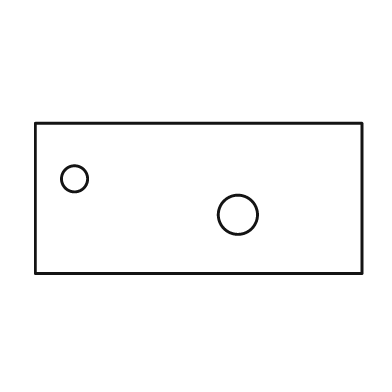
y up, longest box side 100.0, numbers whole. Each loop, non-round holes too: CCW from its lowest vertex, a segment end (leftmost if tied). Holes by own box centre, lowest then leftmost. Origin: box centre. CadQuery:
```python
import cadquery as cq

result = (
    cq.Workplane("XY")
    .moveTo(-50.0, -23.0)
    .lineTo(50.0, -23.0)
    .lineTo(50.0, 23.0)
    .lineTo(-50.0, 23.0)
    .close()
    .moveTo(12.0, -5.0)
    .circle(6.0)
    .moveTo(-38.0, 6.0)
    .circle(4.0)
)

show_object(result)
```